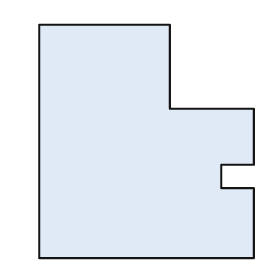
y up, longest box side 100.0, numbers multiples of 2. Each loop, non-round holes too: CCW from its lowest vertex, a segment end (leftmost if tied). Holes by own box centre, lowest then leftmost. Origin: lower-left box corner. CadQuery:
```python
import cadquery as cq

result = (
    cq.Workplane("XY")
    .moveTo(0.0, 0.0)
    .lineTo(92.0, 0.0)
    .lineTo(92.0, 30.0)
    .lineTo(78.0, 30.0)
    .lineTo(78.0, 40.0)
    .lineTo(92.0, 40.0)
    .lineTo(92.0, 64.0)
    .lineTo(56.0, 64.0)
    .lineTo(56.0, 100.0)
    .lineTo(0.0, 100.0)
    .close()
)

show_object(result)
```